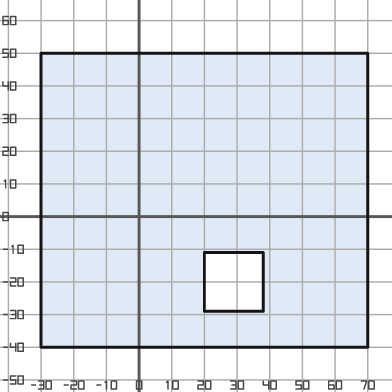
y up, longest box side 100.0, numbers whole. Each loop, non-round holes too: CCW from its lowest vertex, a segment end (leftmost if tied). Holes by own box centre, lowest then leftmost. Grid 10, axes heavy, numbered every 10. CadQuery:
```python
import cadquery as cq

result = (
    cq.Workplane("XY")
    .moveTo(-30.0, -40.0)
    .lineTo(70.0, -40.0)
    .lineTo(70.0, 50.0)
    .lineTo(-30.0, 50.0)
    .close()
    .moveTo(20.0, -29.0)
    .lineTo(38.0, -29.0)
    .lineTo(38.0, -11.0)
    .lineTo(20.0, -11.0)
    .close()
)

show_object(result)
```